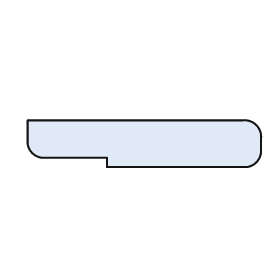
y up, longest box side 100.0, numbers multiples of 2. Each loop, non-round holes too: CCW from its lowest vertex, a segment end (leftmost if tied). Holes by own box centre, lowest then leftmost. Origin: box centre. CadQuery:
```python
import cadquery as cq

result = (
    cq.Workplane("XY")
    .moveTo(-16.0, -10.0)
    .lineTo(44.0, -10.0)
    .threePointArc((48.0, -8.0), (50.0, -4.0))
    .lineTo(50.0, 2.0)
    .threePointArc((48.0, 8.0), (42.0, 10.0))
    .lineTo(-50.0, 10.0)
    .lineTo(-50.0, 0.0)
    .threePointArc((-48.0, -4.0), (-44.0, -6.0))
    .lineTo(-16.0, -6.0)
    .close()
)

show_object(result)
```